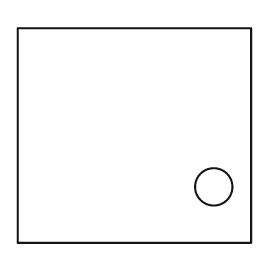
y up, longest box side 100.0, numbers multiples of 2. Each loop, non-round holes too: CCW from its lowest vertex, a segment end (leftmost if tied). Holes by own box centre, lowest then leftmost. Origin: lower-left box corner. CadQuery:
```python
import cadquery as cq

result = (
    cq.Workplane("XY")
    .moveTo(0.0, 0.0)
    .lineTo(100.0, 0.0)
    .lineTo(100.0, 92.0)
    .lineTo(0.0, 92.0)
    .close()
    .moveTo(84.0, 24.0)
    .circle(8.0)
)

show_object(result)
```